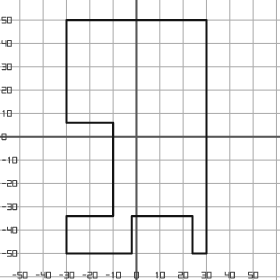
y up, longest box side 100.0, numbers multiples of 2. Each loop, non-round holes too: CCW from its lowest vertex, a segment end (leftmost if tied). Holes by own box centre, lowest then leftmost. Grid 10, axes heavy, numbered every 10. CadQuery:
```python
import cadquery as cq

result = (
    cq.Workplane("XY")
    .moveTo(-30.0, -50.0)
    .lineTo(-2.0, -50.0)
    .lineTo(-2.0, -34.0)
    .lineTo(24.0, -34.0)
    .lineTo(24.0, -50.0)
    .lineTo(30.0, -50.0)
    .lineTo(30.0, 50.0)
    .lineTo(-30.0, 50.0)
    .lineTo(-30.0, 6.0)
    .lineTo(-10.0, 6.0)
    .lineTo(-10.0, -34.0)
    .lineTo(-30.0, -34.0)
    .close()
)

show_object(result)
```